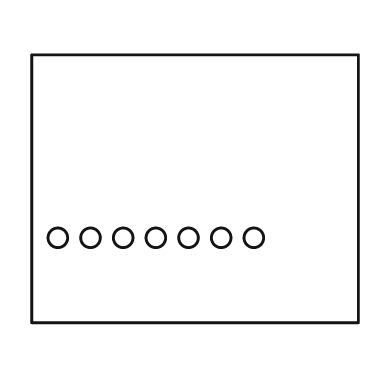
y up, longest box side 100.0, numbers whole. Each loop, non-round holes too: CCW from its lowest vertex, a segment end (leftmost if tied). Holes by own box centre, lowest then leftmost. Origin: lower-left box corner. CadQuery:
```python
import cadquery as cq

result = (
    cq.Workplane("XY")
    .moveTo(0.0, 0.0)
    .lineTo(100.0, 0.0)
    .lineTo(100.0, 82.0)
    .lineTo(0.0, 82.0)
    .close()
    .moveTo(8.0, 26.0)
    .circle(3.0)
    .moveTo(18.0, 26.0)
    .circle(3.0)
    .moveTo(28.0, 26.0)
    .circle(3.0)
    .moveTo(38.0, 26.0)
    .circle(3.0)
    .moveTo(48.0, 26.0)
    .circle(3.0)
    .moveTo(58.0, 26.0)
    .circle(3.0)
    .moveTo(68.0, 26.0)
    .circle(3.0)
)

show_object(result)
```